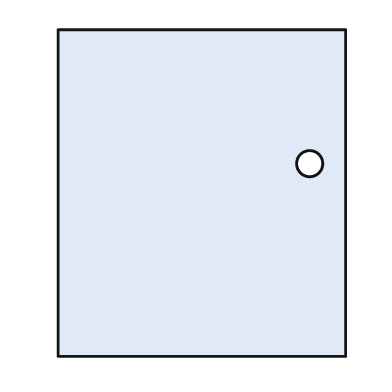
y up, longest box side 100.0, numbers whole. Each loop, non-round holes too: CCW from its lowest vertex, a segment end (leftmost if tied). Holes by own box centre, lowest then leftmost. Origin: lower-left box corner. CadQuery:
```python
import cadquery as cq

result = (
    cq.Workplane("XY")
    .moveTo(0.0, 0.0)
    .lineTo(88.0, 0.0)
    .lineTo(88.0, 100.0)
    .lineTo(0.0, 100.0)
    .close()
    .moveTo(77.0, 59.0)
    .circle(4.0)
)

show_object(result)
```